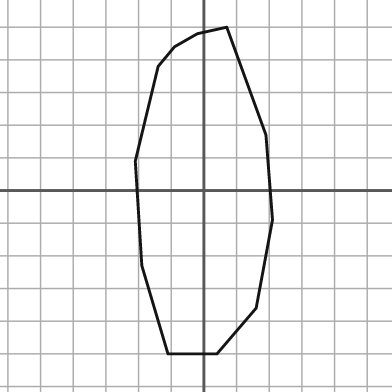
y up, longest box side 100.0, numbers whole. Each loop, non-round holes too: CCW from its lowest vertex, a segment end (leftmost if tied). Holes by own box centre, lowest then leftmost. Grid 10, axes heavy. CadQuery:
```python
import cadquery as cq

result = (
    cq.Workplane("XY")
    .moveTo(-11.0, -50.0)
    .lineTo(4.0, -50.0)
    .lineTo(16.0, -36.0)
    .lineTo(21.0, -9.0)
    .lineTo(19.0, 17.0)
    .lineTo(7.0, 50.0)
    .lineTo(-2.0, 48.0)
    .lineTo(-9.0, 44.0)
    .lineTo(-14.0, 38.0)
    .lineTo(-21.0, 9.0)
    .lineTo(-19.0, -23.0)
    .close()
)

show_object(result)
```